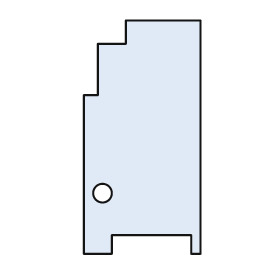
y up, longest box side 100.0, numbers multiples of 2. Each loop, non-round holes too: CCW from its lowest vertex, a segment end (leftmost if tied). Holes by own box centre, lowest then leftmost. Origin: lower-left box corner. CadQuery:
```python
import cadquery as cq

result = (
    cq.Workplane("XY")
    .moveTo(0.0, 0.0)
    .lineTo(12.0, 0.0)
    .lineTo(12.0, 8.0)
    .lineTo(46.0, 8.0)
    .lineTo(46.0, 0.0)
    .lineTo(50.0, 0.0)
    .lineTo(50.0, 100.0)
    .lineTo(18.0, 100.0)
    .lineTo(18.0, 90.0)
    .lineTo(6.0, 90.0)
    .lineTo(6.0, 68.0)
    .lineTo(0.0, 68.0)
    .close()
    .moveTo(8.0, 26.0)
    .circle(4.0)
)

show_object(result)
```